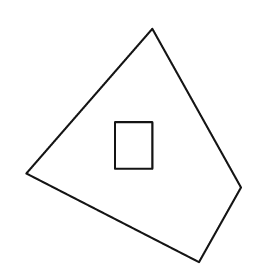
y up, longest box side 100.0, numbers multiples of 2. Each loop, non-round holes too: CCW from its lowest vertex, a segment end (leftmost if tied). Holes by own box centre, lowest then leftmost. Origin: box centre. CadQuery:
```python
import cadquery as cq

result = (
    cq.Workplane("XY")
    .moveTo(28.0, -50.0)
    .lineTo(46.0, -18.0)
    .lineTo(8.0, 50.0)
    .lineTo(-46.0, -12.0)
    .close()
    .moveTo(-8.0, -10.0)
    .lineTo(8.0, -10.0)
    .lineTo(8.0, 10.0)
    .lineTo(-8.0, 10.0)
    .close()
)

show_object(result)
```